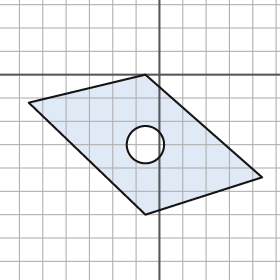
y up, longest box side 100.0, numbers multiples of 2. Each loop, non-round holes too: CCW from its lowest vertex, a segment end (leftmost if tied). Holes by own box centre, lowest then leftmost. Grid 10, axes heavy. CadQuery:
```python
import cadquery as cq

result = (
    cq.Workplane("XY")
    .moveTo(-6.0, -60.0)
    .lineTo(44.0, -44.0)
    .lineTo(-6.0, 0.0)
    .lineTo(-56.0, -12.0)
    .close()
    .moveTo(-6.0, -30.0)
    .circle(8.0)
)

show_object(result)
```